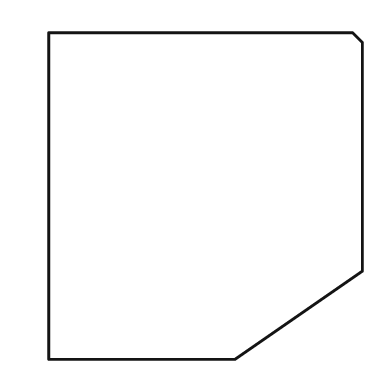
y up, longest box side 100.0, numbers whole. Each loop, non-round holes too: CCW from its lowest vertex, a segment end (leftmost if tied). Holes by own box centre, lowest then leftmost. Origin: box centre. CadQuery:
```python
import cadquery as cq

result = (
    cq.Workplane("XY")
    .moveTo(-48.0, -50.0)
    .lineTo(9.0, -50.0)
    .lineTo(48.0, -23.0)
    .lineTo(48.0, 47.0)
    .lineTo(45.0, 50.0)
    .lineTo(-48.0, 50.0)
    .close()
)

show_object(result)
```